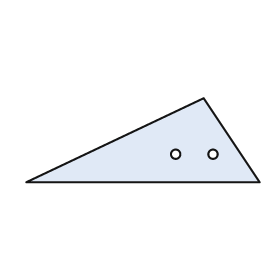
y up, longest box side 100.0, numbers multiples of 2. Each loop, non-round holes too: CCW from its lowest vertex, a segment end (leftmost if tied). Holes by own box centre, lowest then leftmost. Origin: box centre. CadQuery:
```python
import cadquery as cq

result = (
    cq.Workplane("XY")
    .moveTo(-50.0, -18.0)
    .lineTo(50.0, -18.0)
    .lineTo(26.0, 18.0)
    .close()
    .moveTo(14.0, -6.0)
    .circle(2.0)
    .moveTo(30.0, -6.0)
    .circle(2.0)
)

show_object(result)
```